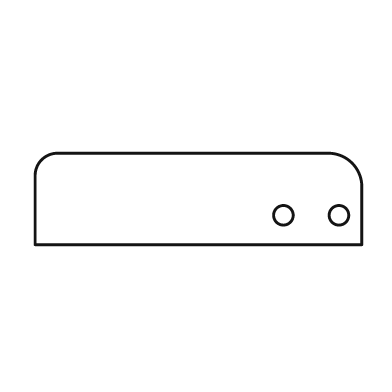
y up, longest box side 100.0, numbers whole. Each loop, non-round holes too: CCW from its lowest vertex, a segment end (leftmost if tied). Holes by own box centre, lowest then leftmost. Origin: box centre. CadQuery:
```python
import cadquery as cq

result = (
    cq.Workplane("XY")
    .moveTo(-50.0, -14.0)
    .lineTo(50.0, -14.0)
    .lineTo(50.0, 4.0)
    .threePointArc((47.0, 11.0), (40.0, 14.0))
    .lineTo(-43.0, 14.0)
    .threePointArc((-48.0, 12.0), (-50.0, 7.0))
    .close()
    .moveTo(26.0, -5.0)
    .circle(3.0)
    .moveTo(43.0, -5.0)
    .circle(3.0)
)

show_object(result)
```